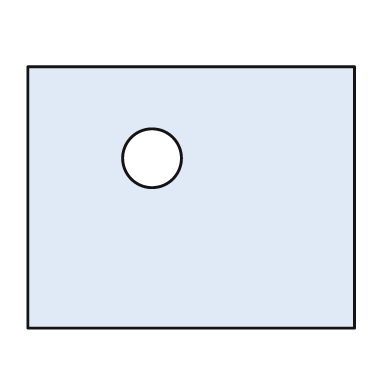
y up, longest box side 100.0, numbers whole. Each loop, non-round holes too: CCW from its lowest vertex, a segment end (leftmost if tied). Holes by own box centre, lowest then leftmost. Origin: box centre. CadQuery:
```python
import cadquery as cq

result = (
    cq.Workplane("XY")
    .moveTo(-50.0, -40.0)
    .lineTo(50.0, -40.0)
    .lineTo(50.0, 40.0)
    .lineTo(-50.0, 40.0)
    .close()
    .moveTo(-12.0, 12.0)
    .circle(9.0)
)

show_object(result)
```